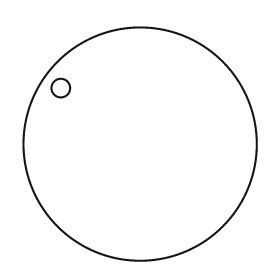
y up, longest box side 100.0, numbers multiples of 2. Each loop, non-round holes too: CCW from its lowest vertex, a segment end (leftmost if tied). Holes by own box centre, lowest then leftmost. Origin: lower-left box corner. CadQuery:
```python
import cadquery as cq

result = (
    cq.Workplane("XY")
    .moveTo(50.0, 50.0)
    .circle(50.0)
    .moveTo(16.0, 74.0)
    .circle(4.0)
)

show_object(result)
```